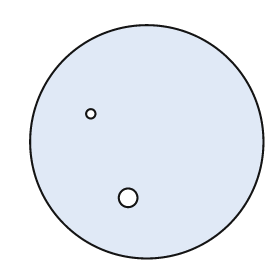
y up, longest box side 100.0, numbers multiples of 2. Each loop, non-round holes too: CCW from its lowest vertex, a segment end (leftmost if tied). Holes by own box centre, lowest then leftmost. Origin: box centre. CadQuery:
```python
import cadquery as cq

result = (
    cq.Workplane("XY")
    .moveTo(0.0, 0.0)
    .circle(50.0)
    .moveTo(-8.0, -24.0)
    .circle(4.0)
    .moveTo(-24.0, 12.0)
    .circle(2.0)
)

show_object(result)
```